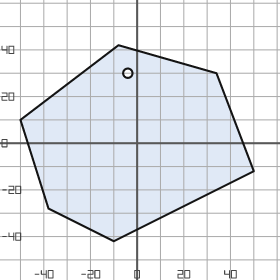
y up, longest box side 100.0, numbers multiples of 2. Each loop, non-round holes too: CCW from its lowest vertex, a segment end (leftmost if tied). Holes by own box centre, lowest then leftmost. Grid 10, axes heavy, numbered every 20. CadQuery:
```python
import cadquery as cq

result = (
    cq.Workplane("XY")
    .moveTo(-10.0, -42.0)
    .lineTo(50.0, -12.0)
    .lineTo(34.0, 30.0)
    .lineTo(-8.0, 42.0)
    .lineTo(-50.0, 10.0)
    .lineTo(-38.0, -28.0)
    .close()
    .moveTo(-4.0, 30.0)
    .circle(2.0)
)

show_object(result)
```